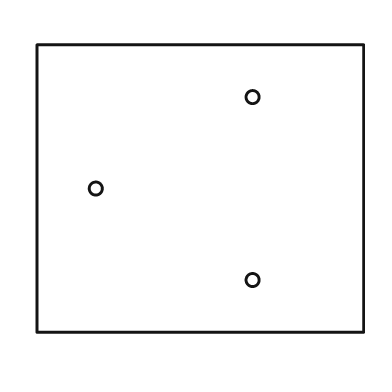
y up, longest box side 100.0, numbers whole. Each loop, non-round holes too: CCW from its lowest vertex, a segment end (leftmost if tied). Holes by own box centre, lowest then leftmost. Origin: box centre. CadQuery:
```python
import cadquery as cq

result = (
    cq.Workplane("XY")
    .moveTo(-50.0, -44.0)
    .lineTo(50.0, -44.0)
    .lineTo(50.0, 44.0)
    .lineTo(-50.0, 44.0)
    .close()
    .moveTo(16.0, -28.0)
    .circle(2.0)
    .moveTo(-32.0, 0.0)
    .circle(2.0)
    .moveTo(16.0, 28.0)
    .circle(2.0)
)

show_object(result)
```